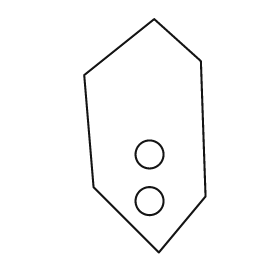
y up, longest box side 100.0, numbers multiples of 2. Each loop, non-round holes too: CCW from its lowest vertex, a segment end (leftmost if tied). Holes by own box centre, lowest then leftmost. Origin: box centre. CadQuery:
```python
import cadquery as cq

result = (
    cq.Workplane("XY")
    .moveTo(6.0, -50.0)
    .lineTo(26.0, -26.0)
    .lineTo(24.0, 32.0)
    .lineTo(4.0, 50.0)
    .lineTo(-26.0, 26.0)
    .lineTo(-22.0, -22.0)
    .close()
    .moveTo(2.0, -28.0)
    .circle(6.0)
    .moveTo(2.0, -8.0)
    .circle(6.0)
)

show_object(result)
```